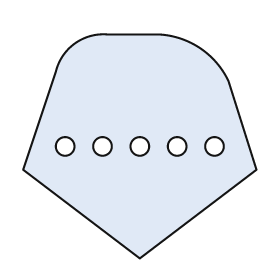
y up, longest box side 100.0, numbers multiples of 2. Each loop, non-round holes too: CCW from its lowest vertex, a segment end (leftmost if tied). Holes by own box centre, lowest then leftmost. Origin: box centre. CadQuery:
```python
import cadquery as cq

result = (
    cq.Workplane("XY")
    .moveTo(0.0, -48.0)
    .lineTo(50.0, -10.0)
    .lineTo(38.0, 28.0)
    .threePointArc((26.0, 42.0), (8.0, 48.0))
    .lineTo(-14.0, 48.0)
    .threePointArc((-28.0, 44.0), (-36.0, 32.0))
    .lineTo(-50.0, -10.0)
    .close()
    .moveTo(-32.0, 0.0)
    .circle(4.0)
    .moveTo(-16.0, 0.0)
    .circle(4.0)
    .moveTo(0.0, 0.0)
    .circle(4.0)
    .moveTo(16.0, 0.0)
    .circle(4.0)
    .moveTo(32.0, 0.0)
    .circle(4.0)
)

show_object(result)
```